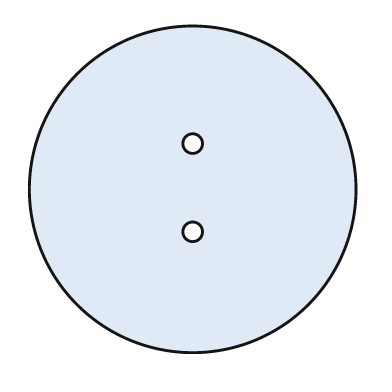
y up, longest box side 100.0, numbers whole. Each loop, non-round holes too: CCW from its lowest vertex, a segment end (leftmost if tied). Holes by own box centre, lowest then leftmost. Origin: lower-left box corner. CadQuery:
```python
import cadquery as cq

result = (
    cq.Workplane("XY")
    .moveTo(50.0, 50.0)
    .circle(50.0)
    .moveTo(50.0, 37.0)
    .circle(3.0)
    .moveTo(50.0, 64.0)
    .circle(3.0)
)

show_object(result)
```